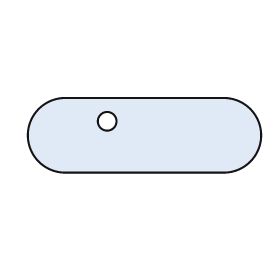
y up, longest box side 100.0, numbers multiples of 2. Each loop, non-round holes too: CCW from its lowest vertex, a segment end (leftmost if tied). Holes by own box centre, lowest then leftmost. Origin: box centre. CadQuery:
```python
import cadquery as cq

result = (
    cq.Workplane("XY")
    .moveTo(-34.0, -16.0)
    .lineTo(34.0, -16.0)
    .threePointArc((50.0, 0.0), (34.0, 16.0))
    .lineTo(-34.0, 16.0)
    .threePointArc((-50.0, 0.0), (-34.0, -16.0))
    .close()
    .moveTo(-16.0, 6.0)
    .circle(4.0)
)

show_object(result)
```